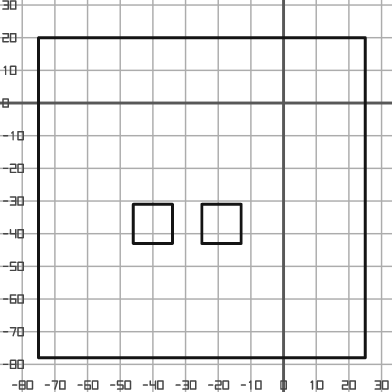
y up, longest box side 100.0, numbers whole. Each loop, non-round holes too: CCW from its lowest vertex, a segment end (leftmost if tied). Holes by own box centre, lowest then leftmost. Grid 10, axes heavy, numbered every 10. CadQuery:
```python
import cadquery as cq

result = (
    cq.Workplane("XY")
    .moveTo(-75.0, -78.0)
    .lineTo(25.0, -78.0)
    .lineTo(25.0, 20.0)
    .lineTo(-75.0, 20.0)
    .close()
    .moveTo(-46.0, -43.0)
    .lineTo(-34.0, -43.0)
    .lineTo(-34.0, -31.0)
    .lineTo(-46.0, -31.0)
    .close()
    .moveTo(-25.0, -43.0)
    .lineTo(-13.0, -43.0)
    .lineTo(-13.0, -31.0)
    .lineTo(-25.0, -31.0)
    .close()
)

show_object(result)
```